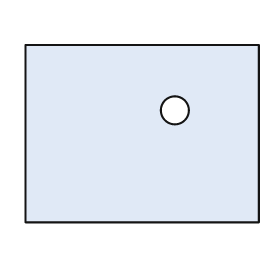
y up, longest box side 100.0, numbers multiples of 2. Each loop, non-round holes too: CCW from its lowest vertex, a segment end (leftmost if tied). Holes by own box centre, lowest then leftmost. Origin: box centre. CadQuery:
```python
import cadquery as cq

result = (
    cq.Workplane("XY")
    .moveTo(-50.0, -38.0)
    .lineTo(50.0, -38.0)
    .lineTo(50.0, 38.0)
    .lineTo(-50.0, 38.0)
    .close()
    .moveTo(14.0, 10.0)
    .circle(6.0)
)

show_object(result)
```